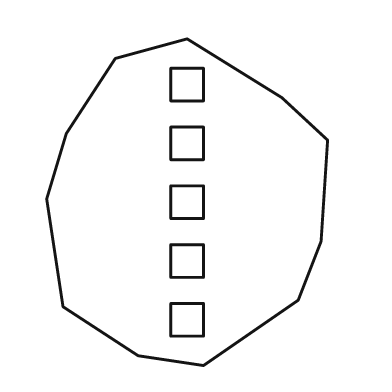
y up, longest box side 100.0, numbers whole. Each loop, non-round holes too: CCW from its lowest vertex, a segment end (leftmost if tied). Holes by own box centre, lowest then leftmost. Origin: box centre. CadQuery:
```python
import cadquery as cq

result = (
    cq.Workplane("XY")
    .moveTo(5.0, -50.0)
    .lineTo(34.0, -30.0)
    .lineTo(41.0, -12.0)
    .lineTo(43.0, 19.0)
    .lineTo(29.0, 32.0)
    .lineTo(0.0, 50.0)
    .lineTo(-22.0, 44.0)
    .lineTo(-37.0, 21.0)
    .lineTo(-43.0, 1.0)
    .lineTo(-38.0, -32.0)
    .lineTo(-15.0, -47.0)
    .close()
    .moveTo(-5.0, -41.0)
    .lineTo(5.0, -41.0)
    .lineTo(5.0, -31.0)
    .lineTo(-5.0, -31.0)
    .close()
    .moveTo(-5.0, -23.0)
    .lineTo(5.0, -23.0)
    .lineTo(5.0, -13.0)
    .lineTo(-5.0, -13.0)
    .close()
    .moveTo(-5.0, -5.0)
    .lineTo(5.0, -5.0)
    .lineTo(5.0, 5.0)
    .lineTo(-5.0, 5.0)
    .close()
    .moveTo(-5.0, 13.0)
    .lineTo(5.0, 13.0)
    .lineTo(5.0, 23.0)
    .lineTo(-5.0, 23.0)
    .close()
    .moveTo(-5.0, 31.0)
    .lineTo(5.0, 31.0)
    .lineTo(5.0, 41.0)
    .lineTo(-5.0, 41.0)
    .close()
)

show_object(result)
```